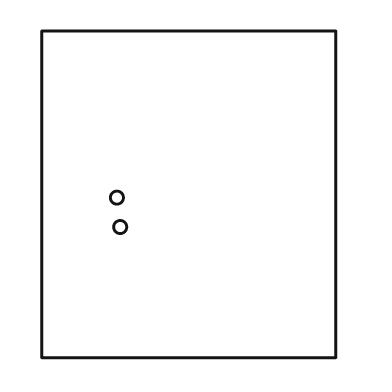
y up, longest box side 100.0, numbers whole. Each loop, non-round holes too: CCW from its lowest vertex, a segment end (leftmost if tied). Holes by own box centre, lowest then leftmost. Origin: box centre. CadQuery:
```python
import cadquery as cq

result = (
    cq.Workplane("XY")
    .moveTo(-45.0, -50.0)
    .lineTo(45.0, -50.0)
    .lineTo(45.0, 50.0)
    .lineTo(-45.0, 50.0)
    .close()
    .moveTo(-21.0, -10.0)
    .circle(2.0)
    .moveTo(-22.0, -1.0)
    .circle(2.0)
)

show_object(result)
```